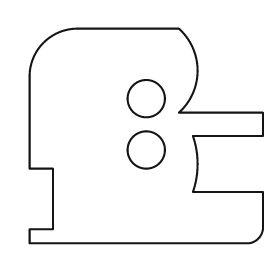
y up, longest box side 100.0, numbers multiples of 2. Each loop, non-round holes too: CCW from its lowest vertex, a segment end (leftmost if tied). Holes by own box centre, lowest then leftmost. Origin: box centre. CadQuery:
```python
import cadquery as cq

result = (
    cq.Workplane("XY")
    .moveTo(-50.0, -46.0)
    .lineTo(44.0, -46.0)
    .threePointArc((48.0, -44.0), (50.0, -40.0))
    .lineTo(50.0, -24.0)
    .lineTo(20.0, -24.0)
    .threePointArc((22.0, -12.0), (20.0, 0.0))
    .lineTo(50.0, 0.0)
    .lineTo(50.0, 10.0)
    .lineTo(14.0, 10.0)
    .threePointArc((22.0, 28.0), (14.0, 46.0))
    .lineTo(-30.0, 46.0)
    .threePointArc((-44.0, 40.0), (-50.0, 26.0))
    .lineTo(-50.0, -14.0)
    .lineTo(-40.0, -14.0)
    .lineTo(-40.0, -40.0)
    .lineTo(-50.0, -40.0)
    .close()
    .moveTo(0.0, -6.0)
    .circle(8.0)
    .moveTo(0.0, 16.0)
    .circle(8.0)
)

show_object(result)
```